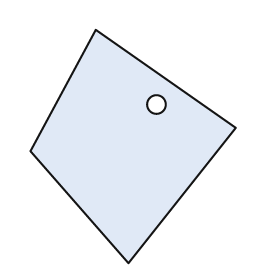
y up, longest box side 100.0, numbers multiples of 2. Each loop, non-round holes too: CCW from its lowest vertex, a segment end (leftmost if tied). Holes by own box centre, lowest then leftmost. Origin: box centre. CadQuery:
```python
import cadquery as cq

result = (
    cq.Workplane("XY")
    .moveTo(-2.0, -50.0)
    .lineTo(44.0, 8.0)
    .lineTo(-16.0, 50.0)
    .lineTo(-44.0, -2.0)
    .close()
    .moveTo(10.0, 18.0)
    .circle(4.0)
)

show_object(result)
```